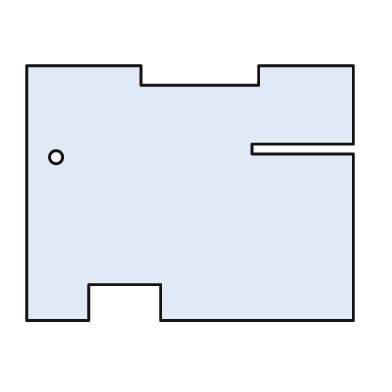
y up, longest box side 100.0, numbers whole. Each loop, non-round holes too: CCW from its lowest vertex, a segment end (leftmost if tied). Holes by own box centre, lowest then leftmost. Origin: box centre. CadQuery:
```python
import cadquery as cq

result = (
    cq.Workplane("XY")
    .moveTo(-50.0, -39.0)
    .lineTo(-31.0, -39.0)
    .lineTo(-31.0, -28.0)
    .lineTo(-9.0, -28.0)
    .lineTo(-9.0, -39.0)
    .lineTo(50.0, -39.0)
    .lineTo(50.0, 12.0)
    .lineTo(19.0, 12.0)
    .lineTo(19.0, 15.0)
    .lineTo(50.0, 15.0)
    .lineTo(50.0, 39.0)
    .lineTo(21.0, 39.0)
    .lineTo(21.0, 33.0)
    .lineTo(-15.0, 33.0)
    .lineTo(-15.0, 39.0)
    .lineTo(-50.0, 39.0)
    .close()
    .moveTo(-41.0, 11.0)
    .circle(2.0)
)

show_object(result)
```